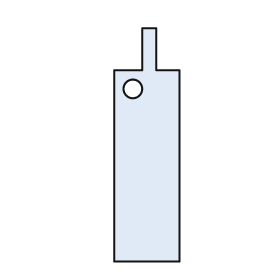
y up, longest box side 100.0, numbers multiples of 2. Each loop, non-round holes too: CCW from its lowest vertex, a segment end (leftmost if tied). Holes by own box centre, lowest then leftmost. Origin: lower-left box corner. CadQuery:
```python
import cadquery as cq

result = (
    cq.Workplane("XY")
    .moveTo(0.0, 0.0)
    .lineTo(28.0, 0.0)
    .lineTo(28.0, 82.0)
    .lineTo(18.0, 82.0)
    .lineTo(18.0, 100.0)
    .lineTo(12.0, 100.0)
    .lineTo(12.0, 82.0)
    .lineTo(0.0, 82.0)
    .close()
    .moveTo(8.0, 74.0)
    .circle(4.0)
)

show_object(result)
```